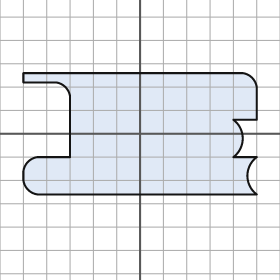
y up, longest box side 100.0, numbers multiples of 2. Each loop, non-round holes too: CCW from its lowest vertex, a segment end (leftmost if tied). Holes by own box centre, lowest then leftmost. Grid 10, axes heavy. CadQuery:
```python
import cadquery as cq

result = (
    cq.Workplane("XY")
    .moveTo(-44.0, -26.0)
    .lineTo(50.0, -26.0)
    .threePointArc((46.0, -18.0), (50.0, -10.0))
    .lineTo(40.0, -10.0)
    .threePointArc((44.0, -2.0), (40.0, 6.0))
    .lineTo(50.0, 6.0)
    .lineTo(50.0, 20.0)
    .threePointArc((48.0, 24.0), (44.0, 26.0))
    .lineTo(-50.0, 26.0)
    .lineTo(-50.0, 22.0)
    .lineTo(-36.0, 22.0)
    .threePointArc((-32.0, 20.0), (-30.0, 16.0))
    .lineTo(-30.0, -10.0)
    .lineTo(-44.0, -10.0)
    .threePointArc((-48.0, -12.0), (-50.0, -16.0))
    .lineTo(-50.0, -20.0)
    .threePointArc((-48.0, -24.0), (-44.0, -26.0))
    .close()
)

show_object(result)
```